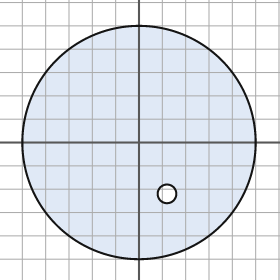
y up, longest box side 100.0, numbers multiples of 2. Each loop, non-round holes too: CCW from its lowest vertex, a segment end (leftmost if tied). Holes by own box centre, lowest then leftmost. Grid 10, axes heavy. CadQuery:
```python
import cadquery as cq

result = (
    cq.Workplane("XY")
    .moveTo(0.0, 0.0)
    .circle(50.0)
    .moveTo(12.0, -22.0)
    .circle(4.0)
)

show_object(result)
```